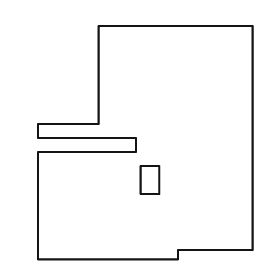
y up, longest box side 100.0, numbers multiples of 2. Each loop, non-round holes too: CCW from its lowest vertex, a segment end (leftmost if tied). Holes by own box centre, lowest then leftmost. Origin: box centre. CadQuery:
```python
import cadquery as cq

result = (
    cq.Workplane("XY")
    .moveTo(-46.0, -50.0)
    .lineTo(14.0, -50.0)
    .lineTo(14.0, -46.0)
    .lineTo(46.0, -46.0)
    .lineTo(46.0, 50.0)
    .lineTo(-20.0, 50.0)
    .lineTo(-20.0, 8.0)
    .lineTo(-46.0, 8.0)
    .lineTo(-46.0, 2.0)
    .lineTo(-4.0, 2.0)
    .lineTo(-4.0, -4.0)
    .lineTo(-46.0, -4.0)
    .close()
    .moveTo(-2.0, -22.0)
    .lineTo(6.0, -22.0)
    .lineTo(6.0, -10.0)
    .lineTo(-2.0, -10.0)
    .close()
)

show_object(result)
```